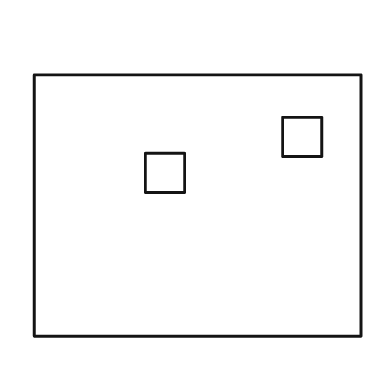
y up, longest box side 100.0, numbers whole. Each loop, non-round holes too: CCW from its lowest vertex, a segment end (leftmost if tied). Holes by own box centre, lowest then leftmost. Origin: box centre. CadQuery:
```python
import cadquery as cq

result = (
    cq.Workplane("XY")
    .moveTo(-50.0, -40.0)
    .lineTo(50.0, -40.0)
    .lineTo(50.0, 40.0)
    .lineTo(-50.0, 40.0)
    .close()
    .moveTo(-16.0, 4.0)
    .lineTo(-4.0, 4.0)
    .lineTo(-4.0, 16.0)
    .lineTo(-16.0, 16.0)
    .close()
    .moveTo(26.0, 15.0)
    .lineTo(38.0, 15.0)
    .lineTo(38.0, 27.0)
    .lineTo(26.0, 27.0)
    .close()
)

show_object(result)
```